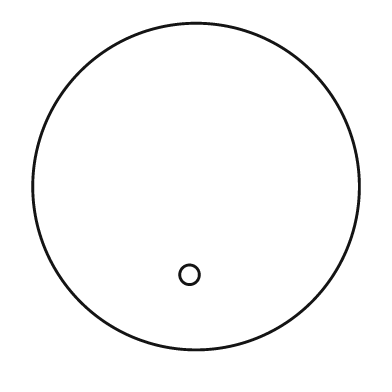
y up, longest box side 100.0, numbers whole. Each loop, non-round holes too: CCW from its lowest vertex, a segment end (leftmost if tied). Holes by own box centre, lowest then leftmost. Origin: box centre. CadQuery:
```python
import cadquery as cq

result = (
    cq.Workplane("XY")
    .moveTo(0.0, 0.0)
    .circle(50.0)
    .moveTo(-2.0, -27.0)
    .circle(3.0)
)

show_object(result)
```